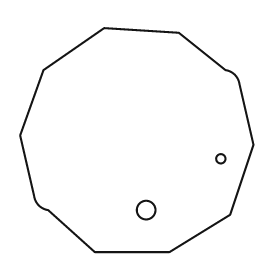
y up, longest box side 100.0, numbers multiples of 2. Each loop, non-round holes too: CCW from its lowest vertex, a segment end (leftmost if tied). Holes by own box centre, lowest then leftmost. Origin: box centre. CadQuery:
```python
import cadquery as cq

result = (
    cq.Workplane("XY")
    .moveTo(-18.0, -48.0)
    .lineTo(14.0, -48.0)
    .lineTo(40.0, -32.0)
    .lineTo(50.0, -2.0)
    .lineTo(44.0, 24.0)
    .threePointArc((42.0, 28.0), (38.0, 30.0))
    .lineTo(18.0, 46.0)
    .lineTo(-14.0, 48.0)
    .lineTo(-40.0, 30.0)
    .lineTo(-50.0, 2.0)
    .lineTo(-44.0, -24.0)
    .threePointArc((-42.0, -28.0), (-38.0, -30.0))
    .close()
    .moveTo(4.0, -30.0)
    .circle(4.0)
    .moveTo(36.0, -8.0)
    .circle(2.0)
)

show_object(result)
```